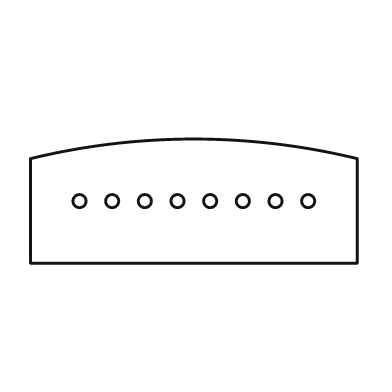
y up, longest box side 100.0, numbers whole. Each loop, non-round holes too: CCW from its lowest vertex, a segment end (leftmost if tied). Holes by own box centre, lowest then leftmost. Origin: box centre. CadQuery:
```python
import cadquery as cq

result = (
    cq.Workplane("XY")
    .moveTo(-50.0, -19.0)
    .lineTo(50.0, -19.0)
    .lineTo(50.0, 13.0)
    .threePointArc((0.0, 19.0), (-50.0, 13.0))
    .close()
    .moveTo(-35.0, 0.0)
    .circle(2.0)
    .moveTo(-25.0, 0.0)
    .circle(2.0)
    .moveTo(-15.0, 0.0)
    .circle(2.0)
    .moveTo(-5.0, 0.0)
    .circle(2.0)
    .moveTo(5.0, 0.0)
    .circle(2.0)
    .moveTo(15.0, 0.0)
    .circle(2.0)
    .moveTo(25.0, 0.0)
    .circle(2.0)
    .moveTo(35.0, 0.0)
    .circle(2.0)
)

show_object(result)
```